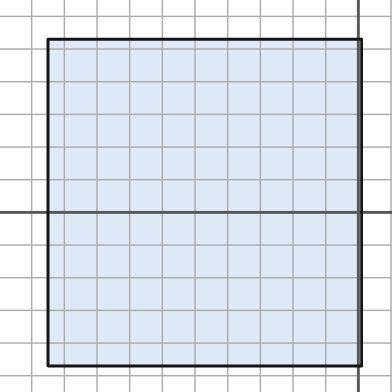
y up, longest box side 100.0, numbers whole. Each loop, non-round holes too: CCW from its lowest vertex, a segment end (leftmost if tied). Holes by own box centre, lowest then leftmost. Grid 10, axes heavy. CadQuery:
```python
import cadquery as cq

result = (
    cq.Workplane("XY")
    .moveTo(-95.0, -47.0)
    .lineTo(1.0, -47.0)
    .lineTo(1.0, 53.0)
    .lineTo(-95.0, 53.0)
    .close()
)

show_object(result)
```